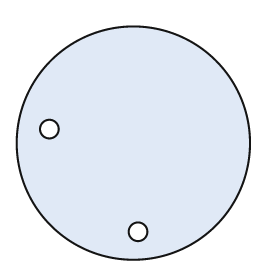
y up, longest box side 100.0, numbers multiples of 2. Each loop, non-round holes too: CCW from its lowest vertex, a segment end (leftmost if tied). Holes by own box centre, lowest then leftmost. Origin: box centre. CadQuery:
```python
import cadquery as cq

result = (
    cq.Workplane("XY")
    .moveTo(0.0, 0.0)
    .circle(50.0)
    .moveTo(2.0, -38.0)
    .circle(4.0)
    .moveTo(-36.0, 6.0)
    .circle(4.0)
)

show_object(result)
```